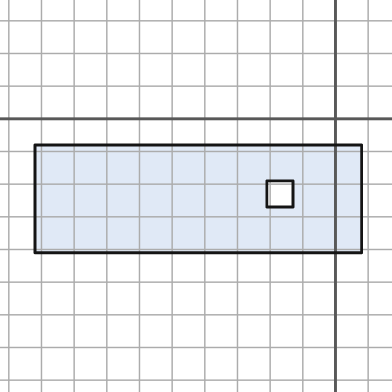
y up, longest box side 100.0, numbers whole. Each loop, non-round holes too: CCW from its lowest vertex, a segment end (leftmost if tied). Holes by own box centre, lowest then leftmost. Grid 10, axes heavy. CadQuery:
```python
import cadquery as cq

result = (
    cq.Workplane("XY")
    .moveTo(-92.0, -41.0)
    .lineTo(8.0, -41.0)
    .lineTo(8.0, -8.0)
    .lineTo(-92.0, -8.0)
    .close()
    .moveTo(-21.0, -27.0)
    .lineTo(-13.0, -27.0)
    .lineTo(-13.0, -19.0)
    .lineTo(-21.0, -19.0)
    .close()
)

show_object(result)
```